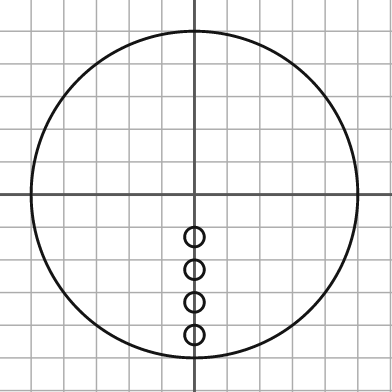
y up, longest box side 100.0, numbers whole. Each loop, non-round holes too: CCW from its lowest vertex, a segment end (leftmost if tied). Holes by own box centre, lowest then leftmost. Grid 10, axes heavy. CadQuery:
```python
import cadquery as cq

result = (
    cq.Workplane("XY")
    .moveTo(0.0, 0.0)
    .circle(50.0)
    .moveTo(0.0, -43.0)
    .circle(3.0)
    .moveTo(0.0, -33.0)
    .circle(3.0)
    .moveTo(0.0, -23.0)
    .circle(3.0)
    .moveTo(0.0, -13.0)
    .circle(3.0)
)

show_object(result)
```